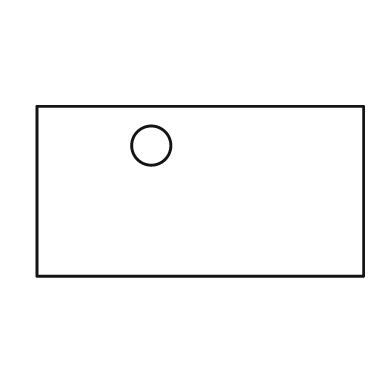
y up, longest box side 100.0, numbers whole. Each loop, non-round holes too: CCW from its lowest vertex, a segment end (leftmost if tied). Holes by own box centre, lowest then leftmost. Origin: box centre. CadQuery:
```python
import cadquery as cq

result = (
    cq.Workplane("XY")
    .moveTo(-50.0, -26.0)
    .lineTo(50.0, -26.0)
    .lineTo(50.0, 26.0)
    .lineTo(-50.0, 26.0)
    .close()
    .moveTo(-15.0, 14.0)
    .circle(6.0)
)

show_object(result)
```